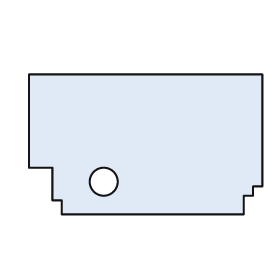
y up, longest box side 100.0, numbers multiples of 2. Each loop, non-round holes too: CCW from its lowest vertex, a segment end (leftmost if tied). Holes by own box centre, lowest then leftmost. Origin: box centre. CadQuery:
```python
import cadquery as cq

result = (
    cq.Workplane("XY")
    .moveTo(-36.0, -30.0)
    .lineTo(42.0, -30.0)
    .lineTo(42.0, -22.0)
    .lineTo(46.0, -22.0)
    .lineTo(46.0, -18.0)
    .lineTo(50.0, -18.0)
    .lineTo(50.0, 30.0)
    .lineTo(-50.0, 30.0)
    .lineTo(-50.0, -10.0)
    .lineTo(-40.0, -10.0)
    .lineTo(-40.0, -24.0)
    .lineTo(-36.0, -24.0)
    .close()
    .moveTo(-18.0, -16.0)
    .circle(6.0)
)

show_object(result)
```